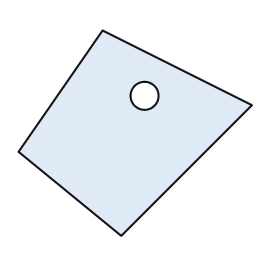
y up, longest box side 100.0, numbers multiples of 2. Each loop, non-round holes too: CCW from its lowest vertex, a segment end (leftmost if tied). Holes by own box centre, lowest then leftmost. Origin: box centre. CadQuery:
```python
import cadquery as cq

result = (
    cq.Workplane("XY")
    .moveTo(-6.0, -44.0)
    .lineTo(50.0, 12.0)
    .lineTo(-14.0, 44.0)
    .lineTo(-50.0, -8.0)
    .close()
    .moveTo(4.0, 16.0)
    .circle(6.0)
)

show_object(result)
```